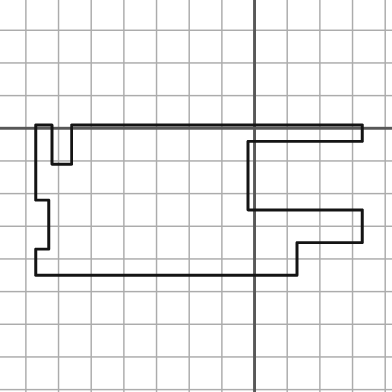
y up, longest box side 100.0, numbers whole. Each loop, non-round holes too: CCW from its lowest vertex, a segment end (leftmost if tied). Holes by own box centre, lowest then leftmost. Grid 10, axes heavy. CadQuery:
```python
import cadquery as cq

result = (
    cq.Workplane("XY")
    .moveTo(-67.0, -45.0)
    .lineTo(13.0, -45.0)
    .lineTo(13.0, -35.0)
    .lineTo(33.0, -35.0)
    .lineTo(33.0, -25.0)
    .lineTo(-2.0, -25.0)
    .lineTo(-2.0, -4.0)
    .lineTo(33.0, -4.0)
    .lineTo(33.0, 1.0)
    .lineTo(-56.0, 1.0)
    .lineTo(-56.0, -11.0)
    .lineTo(-62.0, -11.0)
    .lineTo(-62.0, 1.0)
    .lineTo(-67.0, 1.0)
    .lineTo(-67.0, -22.0)
    .lineTo(-63.0, -22.0)
    .lineTo(-63.0, -37.0)
    .lineTo(-67.0, -37.0)
    .close()
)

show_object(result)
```